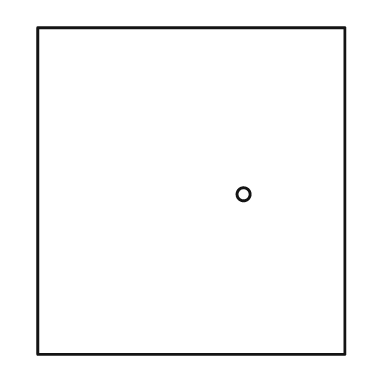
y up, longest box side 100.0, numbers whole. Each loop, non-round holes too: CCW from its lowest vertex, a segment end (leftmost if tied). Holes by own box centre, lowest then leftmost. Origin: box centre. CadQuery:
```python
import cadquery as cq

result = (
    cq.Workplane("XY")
    .moveTo(-47.0, -50.0)
    .lineTo(47.0, -50.0)
    .lineTo(47.0, 50.0)
    .lineTo(-47.0, 50.0)
    .close()
    .moveTo(16.0, -1.0)
    .circle(2.0)
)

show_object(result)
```